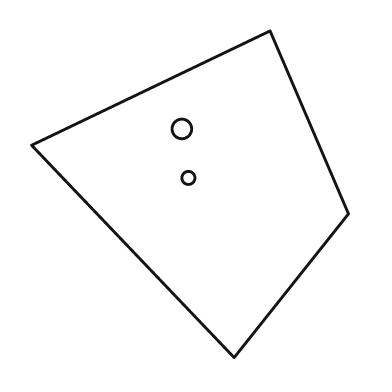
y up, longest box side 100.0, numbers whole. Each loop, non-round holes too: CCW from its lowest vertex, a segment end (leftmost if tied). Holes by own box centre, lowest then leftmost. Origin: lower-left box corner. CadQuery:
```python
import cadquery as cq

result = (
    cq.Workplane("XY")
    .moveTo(62.0, 0.0)
    .lineTo(97.0, 44.0)
    .lineTo(73.0, 100.0)
    .lineTo(0.0, 65.0)
    .close()
    .moveTo(48.0, 55.0)
    .circle(2.0)
    .moveTo(46.0, 70.0)
    .circle(3.0)
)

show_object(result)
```